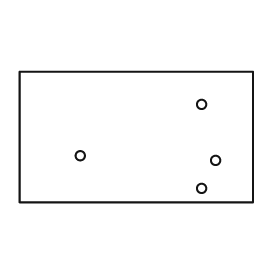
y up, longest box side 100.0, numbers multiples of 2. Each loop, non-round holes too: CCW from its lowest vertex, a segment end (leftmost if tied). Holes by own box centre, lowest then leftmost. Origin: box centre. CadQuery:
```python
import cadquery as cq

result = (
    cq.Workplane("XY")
    .moveTo(-50.0, -28.0)
    .lineTo(50.0, -28.0)
    .lineTo(50.0, 28.0)
    .lineTo(-50.0, 28.0)
    .close()
    .moveTo(28.0, -22.0)
    .circle(2.0)
    .moveTo(34.0, -10.0)
    .circle(2.0)
    .moveTo(-24.0, -8.0)
    .circle(2.0)
    .moveTo(28.0, 14.0)
    .circle(2.0)
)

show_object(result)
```